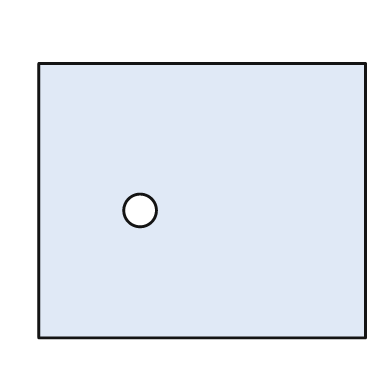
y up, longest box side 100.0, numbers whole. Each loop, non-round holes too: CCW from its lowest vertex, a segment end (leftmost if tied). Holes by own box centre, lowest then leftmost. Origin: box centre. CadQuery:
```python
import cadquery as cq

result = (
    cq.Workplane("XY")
    .moveTo(-50.0, -42.0)
    .lineTo(50.0, -42.0)
    .lineTo(50.0, 42.0)
    .lineTo(-50.0, 42.0)
    .close()
    .moveTo(-19.0, -3.0)
    .circle(5.0)
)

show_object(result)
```